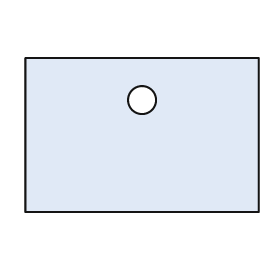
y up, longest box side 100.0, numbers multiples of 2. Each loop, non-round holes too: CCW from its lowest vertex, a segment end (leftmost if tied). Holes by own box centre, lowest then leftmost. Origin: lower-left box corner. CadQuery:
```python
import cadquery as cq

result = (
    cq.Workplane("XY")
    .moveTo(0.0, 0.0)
    .lineTo(100.0, 0.0)
    .lineTo(100.0, 66.0)
    .lineTo(0.0, 66.0)
    .close()
    .moveTo(50.0, 48.0)
    .circle(6.0)
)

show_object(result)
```